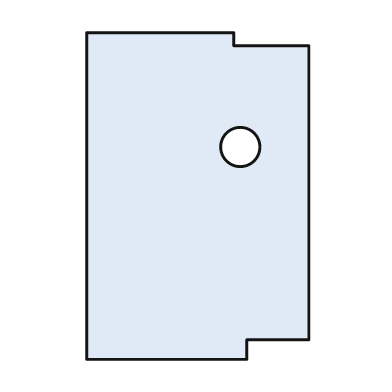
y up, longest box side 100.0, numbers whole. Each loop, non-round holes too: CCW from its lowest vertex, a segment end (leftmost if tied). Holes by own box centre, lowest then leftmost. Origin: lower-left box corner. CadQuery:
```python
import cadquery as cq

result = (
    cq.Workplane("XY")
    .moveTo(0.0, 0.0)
    .lineTo(49.0, 0.0)
    .lineTo(49.0, 6.0)
    .lineTo(68.0, 6.0)
    .lineTo(68.0, 96.0)
    .lineTo(45.0, 96.0)
    .lineTo(45.0, 100.0)
    .lineTo(0.0, 100.0)
    .close()
    .moveTo(47.0, 65.0)
    .circle(6.0)
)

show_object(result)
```